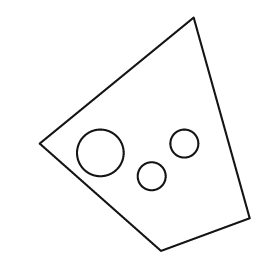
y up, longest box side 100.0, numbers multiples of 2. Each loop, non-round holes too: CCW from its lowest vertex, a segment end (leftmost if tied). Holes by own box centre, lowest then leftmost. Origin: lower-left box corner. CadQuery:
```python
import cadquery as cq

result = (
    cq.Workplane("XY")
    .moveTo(52.0, 0.0)
    .lineTo(90.0, 14.0)
    .lineTo(66.0, 100.0)
    .lineTo(0.0, 46.0)
    .close()
    .moveTo(48.0, 32.0)
    .circle(6.0)
    .moveTo(26.0, 42.0)
    .circle(10.0)
    .moveTo(62.0, 46.0)
    .circle(6.0)
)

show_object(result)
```